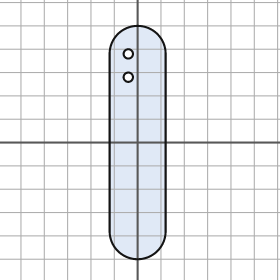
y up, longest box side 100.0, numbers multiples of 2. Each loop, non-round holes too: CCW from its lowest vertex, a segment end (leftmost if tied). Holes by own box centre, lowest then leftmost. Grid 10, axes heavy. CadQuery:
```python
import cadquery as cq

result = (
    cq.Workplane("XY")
    .moveTo(-12.0, -38.0)
    .threePointArc((0.0, -50.0), (12.0, -38.0))
    .lineTo(12.0, 38.0)
    .threePointArc((0.0, 50.0), (-12.0, 38.0))
    .close()
    .moveTo(-4.0, 28.0)
    .circle(2.0)
    .moveTo(-4.0, 38.0)
    .circle(2.0)
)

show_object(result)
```